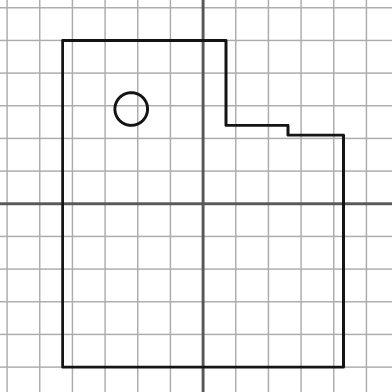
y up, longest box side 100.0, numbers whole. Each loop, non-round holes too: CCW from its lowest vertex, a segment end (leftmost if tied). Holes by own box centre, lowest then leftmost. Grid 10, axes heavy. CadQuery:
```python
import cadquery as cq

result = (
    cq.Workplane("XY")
    .moveTo(-43.0, -50.0)
    .lineTo(43.0, -50.0)
    .lineTo(43.0, 21.0)
    .lineTo(26.0, 21.0)
    .lineTo(26.0, 24.0)
    .lineTo(7.0, 24.0)
    .lineTo(7.0, 50.0)
    .lineTo(-43.0, 50.0)
    .close()
    .moveTo(-22.0, 29.0)
    .circle(5.0)
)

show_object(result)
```